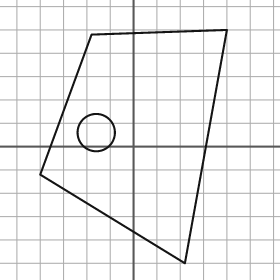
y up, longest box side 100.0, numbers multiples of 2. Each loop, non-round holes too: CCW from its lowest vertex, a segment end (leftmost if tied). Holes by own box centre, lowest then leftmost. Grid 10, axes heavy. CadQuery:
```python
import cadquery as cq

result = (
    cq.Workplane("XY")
    .moveTo(22.0, -50.0)
    .lineTo(40.0, 50.0)
    .lineTo(-18.0, 48.0)
    .lineTo(-40.0, -12.0)
    .close()
    .moveTo(-16.0, 6.0)
    .circle(8.0)
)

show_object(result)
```